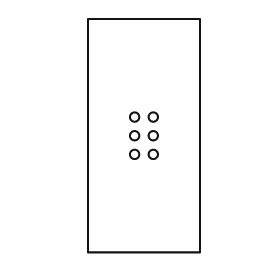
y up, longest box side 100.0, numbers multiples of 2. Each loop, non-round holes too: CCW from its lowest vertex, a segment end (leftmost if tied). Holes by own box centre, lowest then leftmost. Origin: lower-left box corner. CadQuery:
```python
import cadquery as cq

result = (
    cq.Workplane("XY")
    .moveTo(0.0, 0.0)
    .lineTo(48.0, 0.0)
    .lineTo(48.0, 100.0)
    .lineTo(0.0, 100.0)
    .close()
    .moveTo(20.0, 42.0)
    .circle(2.0)
    .moveTo(28.0, 42.0)
    .circle(2.0)
    .moveTo(20.0, 50.0)
    .circle(2.0)
    .moveTo(28.0, 50.0)
    .circle(2.0)
    .moveTo(20.0, 58.0)
    .circle(2.0)
    .moveTo(28.0, 58.0)
    .circle(2.0)
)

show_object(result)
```